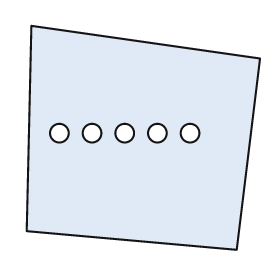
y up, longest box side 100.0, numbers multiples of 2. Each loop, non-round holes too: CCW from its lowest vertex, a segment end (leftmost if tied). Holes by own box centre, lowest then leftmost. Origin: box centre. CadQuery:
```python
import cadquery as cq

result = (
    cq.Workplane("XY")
    .moveTo(40.0, -48.0)
    .lineTo(50.0, 34.0)
    .lineTo(-48.0, 48.0)
    .lineTo(-50.0, -40.0)
    .close()
    .moveTo(-36.0, 2.0)
    .circle(4.0)
    .moveTo(-22.0, 2.0)
    .circle(4.0)
    .moveTo(-8.0, 2.0)
    .circle(4.0)
    .moveTo(6.0, 2.0)
    .circle(4.0)
    .moveTo(20.0, 2.0)
    .circle(4.0)
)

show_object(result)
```